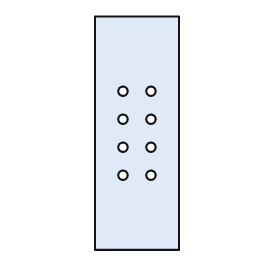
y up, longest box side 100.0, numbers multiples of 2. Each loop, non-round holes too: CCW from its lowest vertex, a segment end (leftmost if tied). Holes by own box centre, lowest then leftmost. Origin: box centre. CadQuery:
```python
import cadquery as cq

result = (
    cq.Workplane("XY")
    .moveTo(-18.0, -50.0)
    .lineTo(18.0, -50.0)
    .lineTo(18.0, 50.0)
    .lineTo(-18.0, 50.0)
    .close()
    .moveTo(-6.0, -18.0)
    .circle(2.0)
    .moveTo(6.0, -18.0)
    .circle(2.0)
    .moveTo(-6.0, -6.0)
    .circle(2.0)
    .moveTo(6.0, -6.0)
    .circle(2.0)
    .moveTo(-6.0, 6.0)
    .circle(2.0)
    .moveTo(6.0, 6.0)
    .circle(2.0)
    .moveTo(-6.0, 18.0)
    .circle(2.0)
    .moveTo(6.0, 18.0)
    .circle(2.0)
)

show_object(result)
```